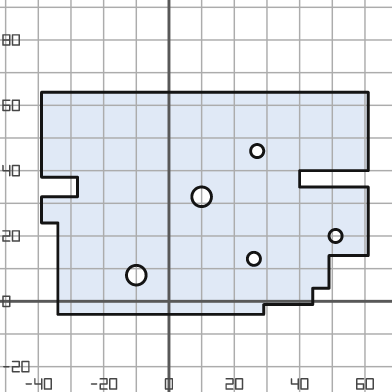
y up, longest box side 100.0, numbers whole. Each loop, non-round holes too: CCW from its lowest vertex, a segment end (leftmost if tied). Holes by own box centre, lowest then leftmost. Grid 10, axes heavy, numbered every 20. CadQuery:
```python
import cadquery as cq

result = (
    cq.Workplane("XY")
    .moveTo(-34.0, -4.0)
    .lineTo(29.0, -4.0)
    .lineTo(29.0, -1.0)
    .lineTo(44.0, -1.0)
    .lineTo(44.0, 4.0)
    .lineTo(49.0, 4.0)
    .lineTo(49.0, 14.0)
    .lineTo(61.0, 14.0)
    .lineTo(61.0, 35.0)
    .lineTo(40.0, 35.0)
    .lineTo(40.0, 40.0)
    .lineTo(61.0, 40.0)
    .lineTo(61.0, 64.0)
    .lineTo(-39.0, 64.0)
    .lineTo(-39.0, 38.0)
    .lineTo(-28.0, 38.0)
    .lineTo(-28.0, 32.0)
    .lineTo(-39.0, 32.0)
    .lineTo(-39.0, 24.0)
    .lineTo(-34.0, 24.0)
    .close()
    .moveTo(-10.0, 8.0)
    .circle(3.0)
    .moveTo(26.0, 13.0)
    .circle(2.0)
    .moveTo(51.0, 20.0)
    .circle(2.0)
    .moveTo(10.0, 32.0)
    .circle(3.0)
    .moveTo(27.0, 46.0)
    .circle(2.0)
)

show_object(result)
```